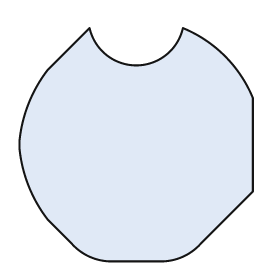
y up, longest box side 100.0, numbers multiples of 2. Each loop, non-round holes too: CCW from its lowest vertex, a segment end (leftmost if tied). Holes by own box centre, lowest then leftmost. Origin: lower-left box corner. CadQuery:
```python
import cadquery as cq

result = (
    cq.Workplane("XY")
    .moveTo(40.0, 0.0)
    .lineTo(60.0, 0.0)
    .threePointArc((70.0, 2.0), (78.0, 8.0))
    .lineTo(100.0, 30.0)
    .lineTo(100.0, 70.0)
    .threePointArc((88.0, 88.0), (70.0, 100.0))
    .threePointArc((50.0, 84.0), (30.0, 100.0))
    .lineTo(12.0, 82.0)
    .threePointArc((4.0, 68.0), (0.0, 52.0))
    .lineTo(0.0, 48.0)
    .threePointArc((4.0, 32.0), (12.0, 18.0))
    .lineTo(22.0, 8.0)
    .threePointArc((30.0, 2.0), (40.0, 0.0))
    .close()
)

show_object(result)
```